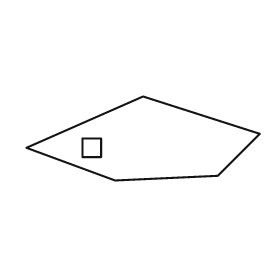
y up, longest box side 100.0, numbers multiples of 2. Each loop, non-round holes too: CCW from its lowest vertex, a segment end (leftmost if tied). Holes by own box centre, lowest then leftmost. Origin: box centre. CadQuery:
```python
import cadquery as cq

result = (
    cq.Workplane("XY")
    .moveTo(-12.0, -18.0)
    .lineTo(32.0, -16.0)
    .lineTo(50.0, 2.0)
    .lineTo(0.0, 18.0)
    .lineTo(-50.0, -4.0)
    .close()
    .moveTo(-26.0, -8.0)
    .lineTo(-18.0, -8.0)
    .lineTo(-18.0, 0.0)
    .lineTo(-26.0, 0.0)
    .close()
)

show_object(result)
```